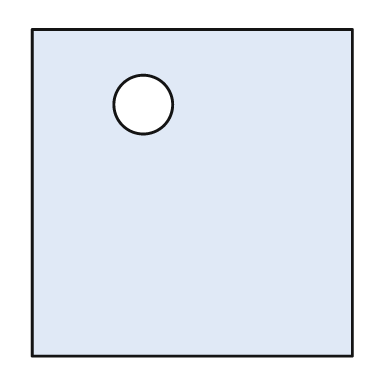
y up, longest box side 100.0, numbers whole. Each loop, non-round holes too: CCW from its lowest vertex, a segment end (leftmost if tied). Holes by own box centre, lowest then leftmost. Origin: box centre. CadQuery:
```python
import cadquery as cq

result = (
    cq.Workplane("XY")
    .moveTo(-49.0, -50.0)
    .lineTo(49.0, -50.0)
    .lineTo(49.0, 50.0)
    .lineTo(-49.0, 50.0)
    .close()
    .moveTo(-15.0, 27.0)
    .circle(9.0)
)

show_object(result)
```